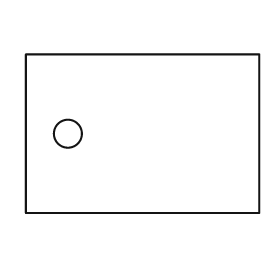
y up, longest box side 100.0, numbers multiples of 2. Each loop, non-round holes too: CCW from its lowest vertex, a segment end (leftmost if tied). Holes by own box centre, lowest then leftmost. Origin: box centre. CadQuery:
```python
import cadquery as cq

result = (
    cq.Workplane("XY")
    .moveTo(-50.0, -34.0)
    .lineTo(50.0, -34.0)
    .lineTo(50.0, 34.0)
    .lineTo(-50.0, 34.0)
    .close()
    .moveTo(-32.0, 0.0)
    .circle(6.0)
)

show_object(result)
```